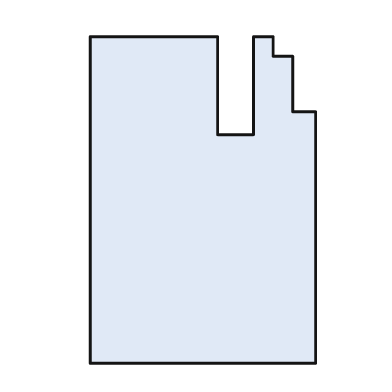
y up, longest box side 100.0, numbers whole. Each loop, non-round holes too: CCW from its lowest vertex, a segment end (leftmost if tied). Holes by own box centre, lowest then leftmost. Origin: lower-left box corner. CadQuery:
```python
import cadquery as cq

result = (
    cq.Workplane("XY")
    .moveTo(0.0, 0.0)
    .lineTo(69.0, 0.0)
    .lineTo(69.0, 77.0)
    .lineTo(62.0, 77.0)
    .lineTo(62.0, 94.0)
    .lineTo(56.0, 94.0)
    .lineTo(56.0, 100.0)
    .lineTo(50.0, 100.0)
    .lineTo(50.0, 70.0)
    .lineTo(39.0, 70.0)
    .lineTo(39.0, 100.0)
    .lineTo(0.0, 100.0)
    .close()
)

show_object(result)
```